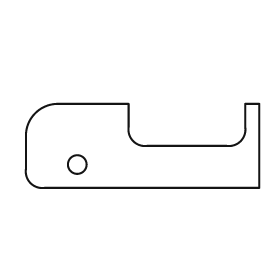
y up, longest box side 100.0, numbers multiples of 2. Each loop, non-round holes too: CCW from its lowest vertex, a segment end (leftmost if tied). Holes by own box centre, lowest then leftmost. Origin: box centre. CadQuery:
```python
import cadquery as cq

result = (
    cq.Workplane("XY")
    .moveTo(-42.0, -18.0)
    .lineTo(50.0, -18.0)
    .lineTo(50.0, 18.0)
    .lineTo(44.0, 18.0)
    .lineTo(44.0, 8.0)
    .threePointArc((42.0, 2.0), (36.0, 0.0))
    .lineTo(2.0, 0.0)
    .threePointArc((-4.0, 2.0), (-6.0, 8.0))
    .lineTo(-6.0, 18.0)
    .lineTo(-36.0, 18.0)
    .threePointArc((-46.0, 14.0), (-50.0, 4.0))
    .lineTo(-50.0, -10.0)
    .threePointArc((-48.0, -16.0), (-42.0, -18.0))
    .close()
    .moveTo(-28.0, -8.0)
    .circle(4.0)
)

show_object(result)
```